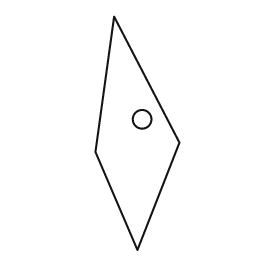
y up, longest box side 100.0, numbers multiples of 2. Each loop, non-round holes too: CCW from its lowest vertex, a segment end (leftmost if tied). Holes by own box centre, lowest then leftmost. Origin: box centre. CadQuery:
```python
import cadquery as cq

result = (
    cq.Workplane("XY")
    .moveTo(0.0, -50.0)
    .lineTo(18.0, -4.0)
    .lineTo(-10.0, 50.0)
    .lineTo(-18.0, -8.0)
    .close()
    .moveTo(2.0, 6.0)
    .circle(4.0)
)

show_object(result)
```